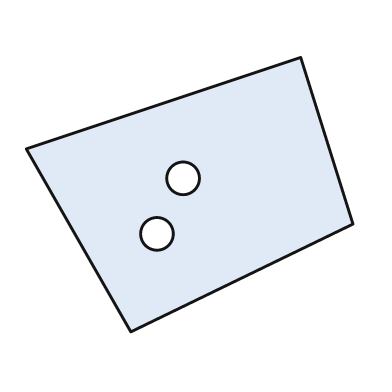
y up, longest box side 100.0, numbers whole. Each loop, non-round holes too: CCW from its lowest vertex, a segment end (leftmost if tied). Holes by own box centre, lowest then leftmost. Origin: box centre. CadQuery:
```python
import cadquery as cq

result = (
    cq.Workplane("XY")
    .moveTo(-18.0, -42.0)
    .lineTo(50.0, -9.0)
    .lineTo(34.0, 42.0)
    .lineTo(-50.0, 14.0)
    .close()
    .moveTo(-10.0, -12.0)
    .circle(5.0)
    .moveTo(-2.0, 5.0)
    .circle(5.0)
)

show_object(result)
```